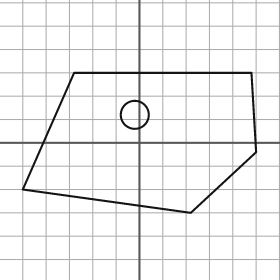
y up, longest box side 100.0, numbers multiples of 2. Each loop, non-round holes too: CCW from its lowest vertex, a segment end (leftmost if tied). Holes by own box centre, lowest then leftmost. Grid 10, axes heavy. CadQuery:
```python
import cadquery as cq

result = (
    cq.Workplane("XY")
    .moveTo(22.0, -30.0)
    .lineTo(50.0, -4.0)
    .lineTo(48.0, 30.0)
    .lineTo(-28.0, 30.0)
    .lineTo(-50.0, -20.0)
    .close()
    .moveTo(-2.0, 12.0)
    .circle(6.0)
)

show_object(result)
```